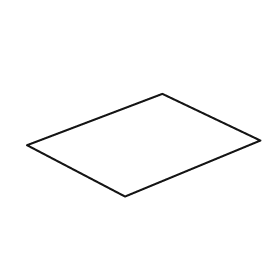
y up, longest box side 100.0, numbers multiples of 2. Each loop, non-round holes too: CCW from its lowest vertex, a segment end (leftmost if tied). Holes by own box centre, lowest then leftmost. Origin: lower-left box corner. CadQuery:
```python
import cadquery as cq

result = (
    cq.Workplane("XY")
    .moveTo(42.0, 0.0)
    .lineTo(100.0, 24.0)
    .lineTo(58.0, 44.0)
    .lineTo(0.0, 22.0)
    .close()
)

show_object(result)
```